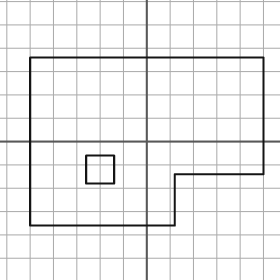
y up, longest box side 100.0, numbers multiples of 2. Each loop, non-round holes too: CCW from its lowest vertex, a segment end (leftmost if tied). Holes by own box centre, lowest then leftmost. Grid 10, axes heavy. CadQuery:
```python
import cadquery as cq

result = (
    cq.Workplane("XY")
    .moveTo(-50.0, -36.0)
    .lineTo(12.0, -36.0)
    .lineTo(12.0, -14.0)
    .lineTo(50.0, -14.0)
    .lineTo(50.0, 36.0)
    .lineTo(-50.0, 36.0)
    .close()
    .moveTo(-26.0, -18.0)
    .lineTo(-14.0, -18.0)
    .lineTo(-14.0, -6.0)
    .lineTo(-26.0, -6.0)
    .close()
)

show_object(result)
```